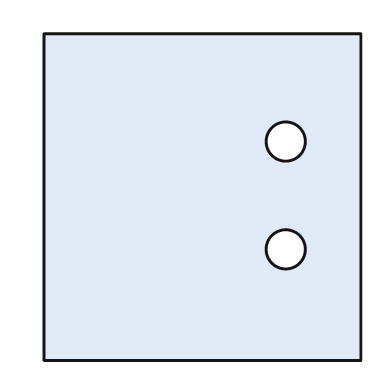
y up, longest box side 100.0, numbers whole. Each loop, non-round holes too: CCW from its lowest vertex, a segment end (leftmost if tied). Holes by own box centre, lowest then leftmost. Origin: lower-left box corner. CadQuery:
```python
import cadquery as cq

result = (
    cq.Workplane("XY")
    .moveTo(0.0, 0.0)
    .lineTo(97.0, 0.0)
    .lineTo(97.0, 100.0)
    .lineTo(0.0, 100.0)
    .close()
    .moveTo(74.0, 34.0)
    .circle(6.0)
    .moveTo(74.0, 67.0)
    .circle(6.0)
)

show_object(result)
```